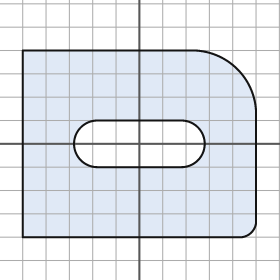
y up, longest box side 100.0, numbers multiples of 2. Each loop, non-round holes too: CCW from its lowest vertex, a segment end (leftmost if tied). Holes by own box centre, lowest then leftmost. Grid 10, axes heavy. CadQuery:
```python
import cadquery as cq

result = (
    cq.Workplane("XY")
    .moveTo(-50.0, -40.0)
    .lineTo(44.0, -40.0)
    .threePointArc((48.0, -38.0), (50.0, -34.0))
    .lineTo(50.0, 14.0)
    .threePointArc((42.0, 32.0), (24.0, 40.0))
    .lineTo(-50.0, 40.0)
    .close()
    .moveTo(-18.0, -10.0)
    .lineTo(18.0, -10.0)
    .threePointArc((28.0, 0.0), (18.0, 10.0))
    .lineTo(-18.0, 10.0)
    .threePointArc((-28.0, 0.0), (-18.0, -10.0))
    .close()
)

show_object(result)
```